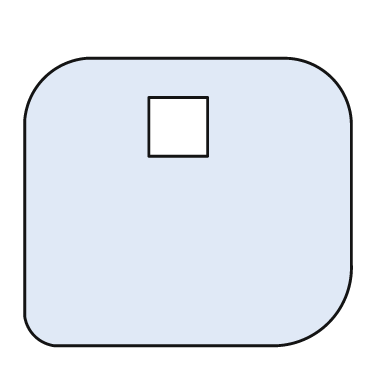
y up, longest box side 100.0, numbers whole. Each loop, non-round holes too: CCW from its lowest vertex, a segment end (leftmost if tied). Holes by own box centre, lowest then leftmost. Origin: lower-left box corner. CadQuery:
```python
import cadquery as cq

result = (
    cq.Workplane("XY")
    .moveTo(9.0, 0.0)
    .lineTo(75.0, 0.0)
    .threePointArc((93.0, 7.0), (100.0, 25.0))
    .lineTo(100.0, 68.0)
    .threePointArc((94.0, 82.0), (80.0, 88.0))
    .lineTo(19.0, 88.0)
    .threePointArc((6.0, 82.0), (0.0, 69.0))
    .lineTo(0.0, 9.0)
    .threePointArc((3.0, 3.0), (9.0, 0.0))
    .close()
    .moveTo(38.0, 58.0)
    .lineTo(56.0, 58.0)
    .lineTo(56.0, 76.0)
    .lineTo(38.0, 76.0)
    .close()
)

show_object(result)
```